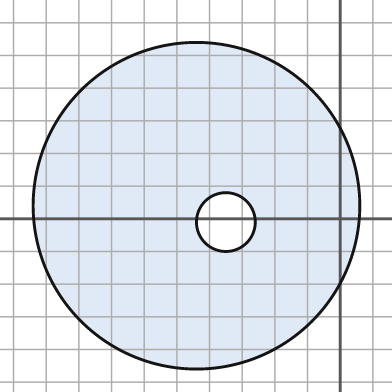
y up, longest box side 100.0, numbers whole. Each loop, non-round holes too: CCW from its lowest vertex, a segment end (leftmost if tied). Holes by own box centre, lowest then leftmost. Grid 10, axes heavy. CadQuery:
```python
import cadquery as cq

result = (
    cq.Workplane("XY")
    .moveTo(-44.0, 4.0)
    .circle(50.0)
    .moveTo(-35.0, -1.0)
    .circle(9.0)
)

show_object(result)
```